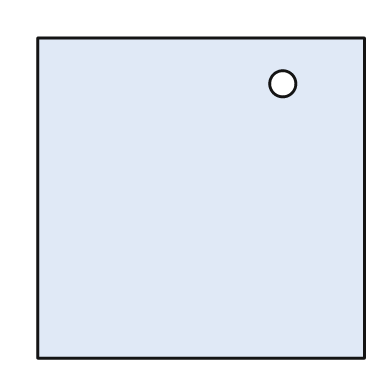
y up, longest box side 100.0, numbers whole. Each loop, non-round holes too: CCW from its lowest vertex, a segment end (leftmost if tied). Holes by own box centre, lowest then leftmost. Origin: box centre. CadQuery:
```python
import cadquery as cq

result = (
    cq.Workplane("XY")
    .moveTo(-50.0, -49.0)
    .lineTo(50.0, -49.0)
    .lineTo(50.0, 49.0)
    .lineTo(-50.0, 49.0)
    .close()
    .moveTo(25.0, 35.0)
    .circle(4.0)
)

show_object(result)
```